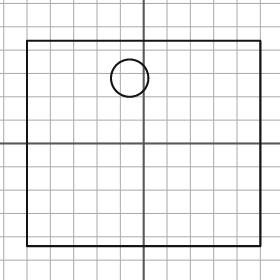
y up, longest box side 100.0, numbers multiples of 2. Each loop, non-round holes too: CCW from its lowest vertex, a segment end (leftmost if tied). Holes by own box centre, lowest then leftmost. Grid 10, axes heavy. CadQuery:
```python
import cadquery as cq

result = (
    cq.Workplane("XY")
    .moveTo(-50.0, -44.0)
    .lineTo(50.0, -44.0)
    .lineTo(50.0, 44.0)
    .lineTo(-50.0, 44.0)
    .close()
    .moveTo(-6.0, 28.0)
    .circle(8.0)
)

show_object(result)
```